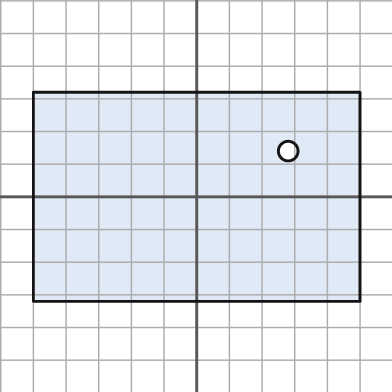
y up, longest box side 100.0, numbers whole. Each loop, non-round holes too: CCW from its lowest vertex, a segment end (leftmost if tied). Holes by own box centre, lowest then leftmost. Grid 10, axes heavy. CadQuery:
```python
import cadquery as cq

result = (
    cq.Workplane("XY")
    .moveTo(-50.0, -32.0)
    .lineTo(50.0, -32.0)
    .lineTo(50.0, 32.0)
    .lineTo(-50.0, 32.0)
    .close()
    .moveTo(28.0, 14.0)
    .circle(3.0)
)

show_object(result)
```